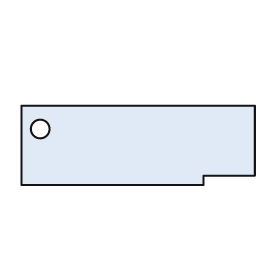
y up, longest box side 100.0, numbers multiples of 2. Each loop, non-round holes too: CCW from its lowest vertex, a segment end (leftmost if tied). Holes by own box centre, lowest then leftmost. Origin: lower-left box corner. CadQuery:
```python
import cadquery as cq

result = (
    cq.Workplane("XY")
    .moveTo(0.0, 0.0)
    .lineTo(78.0, 0.0)
    .lineTo(78.0, 4.0)
    .lineTo(100.0, 4.0)
    .lineTo(100.0, 34.0)
    .lineTo(0.0, 34.0)
    .close()
    .moveTo(8.0, 24.0)
    .circle(4.0)
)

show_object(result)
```